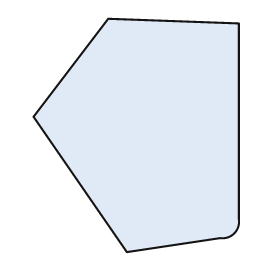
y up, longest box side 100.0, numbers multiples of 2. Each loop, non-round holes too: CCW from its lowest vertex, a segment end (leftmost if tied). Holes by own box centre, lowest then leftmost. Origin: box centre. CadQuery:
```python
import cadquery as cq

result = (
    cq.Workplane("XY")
    .moveTo(-4.0, -50.0)
    .lineTo(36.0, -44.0)
    .threePointArc((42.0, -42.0), (44.0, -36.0))
    .lineTo(44.0, 48.0)
    .lineTo(-12.0, 50.0)
    .lineTo(-44.0, 8.0)
    .close()
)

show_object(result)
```